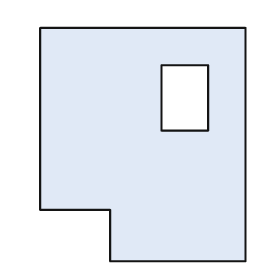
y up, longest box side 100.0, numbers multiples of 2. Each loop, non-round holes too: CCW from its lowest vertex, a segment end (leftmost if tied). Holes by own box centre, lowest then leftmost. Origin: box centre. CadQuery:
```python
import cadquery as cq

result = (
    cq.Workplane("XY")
    .moveTo(-14.0, -50.0)
    .lineTo(44.0, -50.0)
    .lineTo(44.0, 50.0)
    .lineTo(-44.0, 50.0)
    .lineTo(-44.0, -28.0)
    .lineTo(-14.0, -28.0)
    .close()
    .moveTo(8.0, 6.0)
    .lineTo(28.0, 6.0)
    .lineTo(28.0, 34.0)
    .lineTo(8.0, 34.0)
    .close()
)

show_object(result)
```